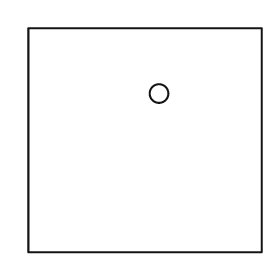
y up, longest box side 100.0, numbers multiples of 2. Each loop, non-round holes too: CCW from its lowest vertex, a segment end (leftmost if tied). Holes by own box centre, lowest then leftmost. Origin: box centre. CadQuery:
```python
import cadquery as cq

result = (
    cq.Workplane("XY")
    .moveTo(-50.0, -48.0)
    .lineTo(50.0, -48.0)
    .lineTo(50.0, 48.0)
    .lineTo(-50.0, 48.0)
    .close()
    .moveTo(6.0, 20.0)
    .circle(4.0)
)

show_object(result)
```